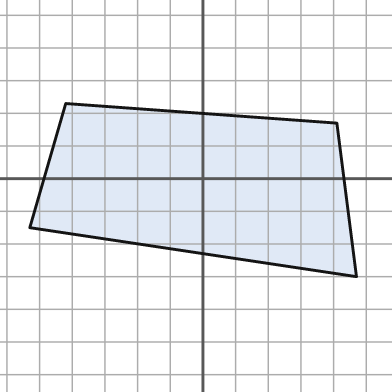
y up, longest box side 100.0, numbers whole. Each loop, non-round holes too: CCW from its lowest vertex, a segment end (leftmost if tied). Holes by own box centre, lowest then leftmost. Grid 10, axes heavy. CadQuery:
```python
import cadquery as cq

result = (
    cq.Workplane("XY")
    .moveTo(47.0, -30.0)
    .lineTo(41.0, 17.0)
    .lineTo(-42.0, 23.0)
    .lineTo(-53.0, -15.0)
    .close()
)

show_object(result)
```